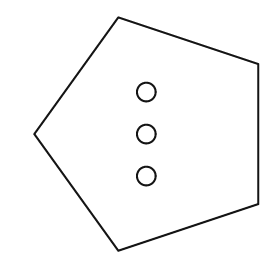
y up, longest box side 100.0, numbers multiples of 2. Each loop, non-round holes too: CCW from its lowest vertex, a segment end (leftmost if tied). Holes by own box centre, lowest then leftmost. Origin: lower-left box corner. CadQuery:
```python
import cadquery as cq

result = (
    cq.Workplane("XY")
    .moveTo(36.0, 0.0)
    .lineTo(96.0, 20.0)
    .lineTo(96.0, 80.0)
    .lineTo(36.0, 100.0)
    .lineTo(0.0, 50.0)
    .close()
    .moveTo(48.0, 32.0)
    .circle(4.0)
    .moveTo(48.0, 50.0)
    .circle(4.0)
    .moveTo(48.0, 68.0)
    .circle(4.0)
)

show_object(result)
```